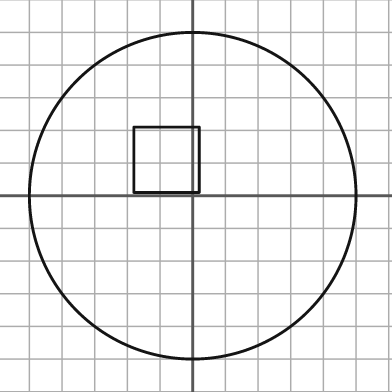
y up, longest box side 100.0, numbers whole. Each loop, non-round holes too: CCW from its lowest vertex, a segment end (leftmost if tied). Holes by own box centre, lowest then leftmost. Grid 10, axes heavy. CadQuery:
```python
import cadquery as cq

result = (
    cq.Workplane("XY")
    .moveTo(0.0, 0.0)
    .circle(50.0)
    .moveTo(-18.0, 1.0)
    .lineTo(2.0, 1.0)
    .lineTo(2.0, 21.0)
    .lineTo(-18.0, 21.0)
    .close()
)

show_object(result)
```